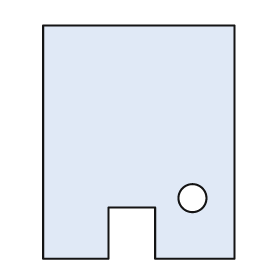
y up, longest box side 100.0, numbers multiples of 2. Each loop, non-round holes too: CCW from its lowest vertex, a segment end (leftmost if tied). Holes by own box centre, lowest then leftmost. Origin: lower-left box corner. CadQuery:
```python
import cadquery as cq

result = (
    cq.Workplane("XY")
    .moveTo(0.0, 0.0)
    .lineTo(28.0, 0.0)
    .lineTo(28.0, 22.0)
    .lineTo(48.0, 22.0)
    .lineTo(48.0, 0.0)
    .lineTo(82.0, 0.0)
    .lineTo(82.0, 100.0)
    .lineTo(0.0, 100.0)
    .close()
    .moveTo(64.0, 26.0)
    .circle(6.0)
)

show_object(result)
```